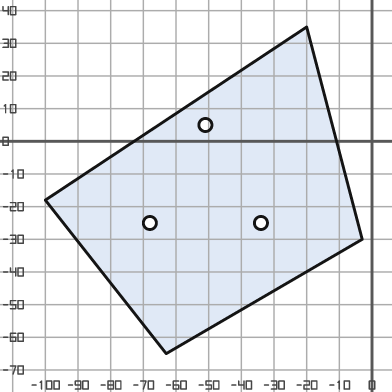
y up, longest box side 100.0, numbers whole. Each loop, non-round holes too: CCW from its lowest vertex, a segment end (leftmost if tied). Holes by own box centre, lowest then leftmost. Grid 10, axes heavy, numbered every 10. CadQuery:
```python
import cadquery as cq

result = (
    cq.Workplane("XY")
    .moveTo(-63.0, -65.0)
    .lineTo(-3.0, -30.0)
    .lineTo(-20.0, 35.0)
    .lineTo(-100.0, -18.0)
    .close()
    .moveTo(-68.0, -25.0)
    .circle(2.0)
    .moveTo(-34.0, -25.0)
    .circle(2.0)
    .moveTo(-51.0, 5.0)
    .circle(2.0)
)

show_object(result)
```